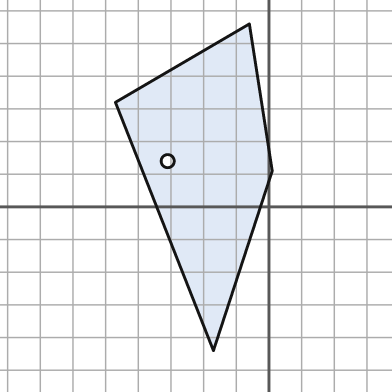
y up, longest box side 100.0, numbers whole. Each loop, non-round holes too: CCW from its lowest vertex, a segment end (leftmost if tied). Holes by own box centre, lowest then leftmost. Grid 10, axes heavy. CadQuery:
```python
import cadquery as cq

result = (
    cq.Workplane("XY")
    .moveTo(-17.0, -44.0)
    .lineTo(1.0, 11.0)
    .lineTo(-6.0, 56.0)
    .lineTo(-47.0, 32.0)
    .close()
    .moveTo(-31.0, 14.0)
    .circle(2.0)
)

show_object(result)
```